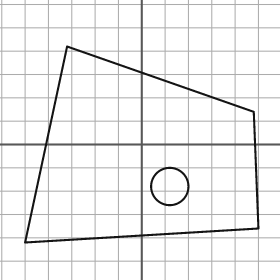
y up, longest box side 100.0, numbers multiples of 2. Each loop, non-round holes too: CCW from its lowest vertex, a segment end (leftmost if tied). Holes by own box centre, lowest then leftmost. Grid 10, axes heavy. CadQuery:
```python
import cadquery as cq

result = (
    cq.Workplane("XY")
    .moveTo(-50.0, -42.0)
    .lineTo(50.0, -36.0)
    .lineTo(48.0, 14.0)
    .lineTo(-32.0, 42.0)
    .close()
    .moveTo(12.0, -18.0)
    .circle(8.0)
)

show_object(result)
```